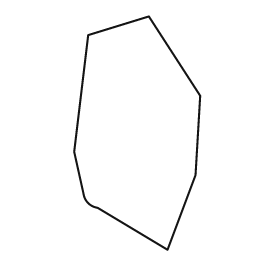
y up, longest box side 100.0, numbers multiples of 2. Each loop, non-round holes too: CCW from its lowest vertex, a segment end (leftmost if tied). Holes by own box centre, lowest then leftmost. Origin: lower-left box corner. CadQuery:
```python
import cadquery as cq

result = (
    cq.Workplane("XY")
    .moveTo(40.0, 0.0)
    .lineTo(52.0, 32.0)
    .lineTo(54.0, 66.0)
    .lineTo(32.0, 100.0)
    .lineTo(6.0, 92.0)
    .lineTo(0.0, 42.0)
    .lineTo(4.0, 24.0)
    .threePointArc((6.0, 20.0), (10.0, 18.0))
    .close()
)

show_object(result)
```